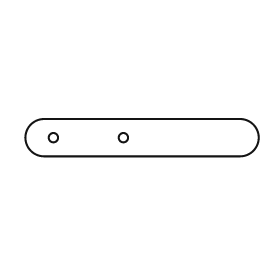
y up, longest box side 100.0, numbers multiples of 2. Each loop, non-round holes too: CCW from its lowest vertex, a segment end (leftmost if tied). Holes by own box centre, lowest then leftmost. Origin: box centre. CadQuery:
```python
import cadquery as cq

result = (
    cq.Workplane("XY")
    .moveTo(-42.0, -8.0)
    .lineTo(42.0, -8.0)
    .threePointArc((50.0, 0.0), (42.0, 8.0))
    .lineTo(-42.0, 8.0)
    .threePointArc((-50.0, 0.0), (-42.0, -8.0))
    .close()
    .moveTo(-38.0, 0.0)
    .circle(2.0)
    .moveTo(-8.0, 0.0)
    .circle(2.0)
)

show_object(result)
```